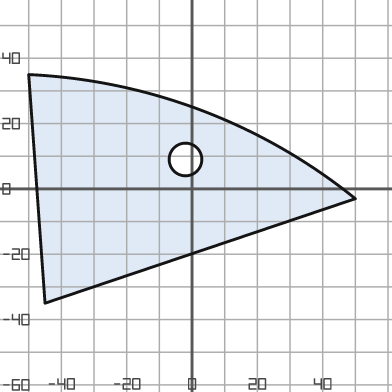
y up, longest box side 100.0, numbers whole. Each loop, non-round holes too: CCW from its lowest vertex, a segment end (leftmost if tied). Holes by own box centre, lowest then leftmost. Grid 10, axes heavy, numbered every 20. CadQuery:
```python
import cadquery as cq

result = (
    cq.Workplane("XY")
    .moveTo(-45.0, -35.0)
    .lineTo(50.0, -3.0)
    .threePointArc((3.0, 24.0), (-50.0, 35.0))
    .close()
    .moveTo(-2.0, 9.0)
    .circle(5.0)
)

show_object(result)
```